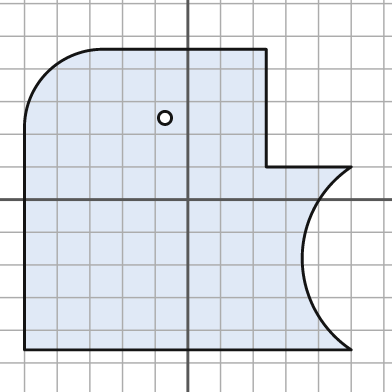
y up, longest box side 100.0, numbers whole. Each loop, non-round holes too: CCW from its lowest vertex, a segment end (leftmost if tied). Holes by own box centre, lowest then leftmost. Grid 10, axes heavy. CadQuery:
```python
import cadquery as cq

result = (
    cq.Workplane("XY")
    .moveTo(-50.0, -46.0)
    .lineTo(50.0, -46.0)
    .threePointArc((35.0, -18.0), (50.0, 10.0))
    .lineTo(24.0, 10.0)
    .lineTo(24.0, 46.0)
    .lineTo(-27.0, 46.0)
    .threePointArc((-43.0, 39.0), (-50.0, 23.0))
    .close()
    .moveTo(-7.0, 25.0)
    .circle(2.0)
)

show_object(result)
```